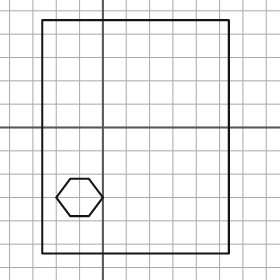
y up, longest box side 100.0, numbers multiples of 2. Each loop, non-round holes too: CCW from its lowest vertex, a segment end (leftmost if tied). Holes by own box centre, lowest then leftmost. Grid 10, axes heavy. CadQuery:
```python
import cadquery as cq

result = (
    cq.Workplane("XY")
    .moveTo(-26.0, -54.0)
    .lineTo(54.0, -54.0)
    .lineTo(54.0, 46.0)
    .lineTo(-26.0, 46.0)
    .close()
    .moveTo(-14.0, -38.0)
    .lineTo(-6.0, -38.0)
    .lineTo(0.0, -30.0)
    .lineTo(-6.0, -22.0)
    .lineTo(-14.0, -22.0)
    .lineTo(-20.0, -30.0)
    .close()
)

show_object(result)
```